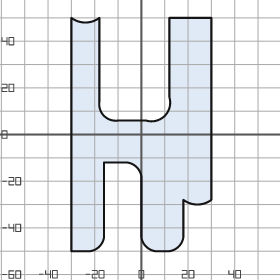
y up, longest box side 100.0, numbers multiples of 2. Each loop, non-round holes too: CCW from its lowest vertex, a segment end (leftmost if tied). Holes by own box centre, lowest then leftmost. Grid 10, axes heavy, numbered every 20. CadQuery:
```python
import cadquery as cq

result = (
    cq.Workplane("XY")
    .moveTo(-30.0, -50.0)
    .lineTo(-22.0, -50.0)
    .threePointArc((-18.0, -48.0), (-16.0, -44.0))
    .lineTo(-16.0, -12.0)
    .lineTo(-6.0, -12.0)
    .threePointArc((-2.0, -14.0), (0.0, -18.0))
    .lineTo(0.0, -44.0)
    .threePointArc((2.0, -48.0), (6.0, -50.0))
    .lineTo(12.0, -50.0)
    .threePointArc((16.0, -48.0), (18.0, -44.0))
    .lineTo(18.0, -28.0)
    .threePointArc((24.0, -30.0), (30.0, -28.0))
    .lineTo(30.0, 50.0)
    .lineTo(12.0, 50.0)
    .lineTo(12.0, 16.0)
    .threePointArc((10.0, 8.0), (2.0, 6.0))
    .lineTo(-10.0, 6.0)
    .threePointArc((-16.0, 8.0), (-18.0, 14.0))
    .lineTo(-18.0, 50.0)
    .threePointArc((-24.0, 48.0), (-30.0, 50.0))
    .close()
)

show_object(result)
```